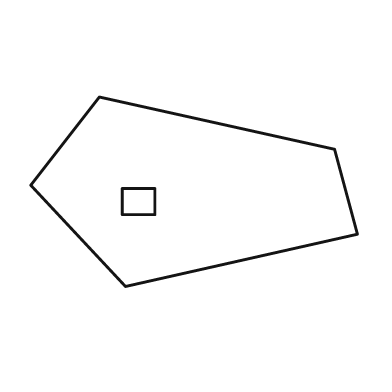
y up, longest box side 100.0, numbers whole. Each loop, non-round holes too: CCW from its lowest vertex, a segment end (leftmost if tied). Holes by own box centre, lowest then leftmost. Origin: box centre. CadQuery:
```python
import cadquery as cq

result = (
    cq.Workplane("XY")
    .moveTo(-21.0, -29.0)
    .lineTo(50.0, -13.0)
    .lineTo(43.0, 13.0)
    .lineTo(-29.0, 29.0)
    .lineTo(-50.0, 2.0)
    .close()
    .moveTo(-22.0, -7.0)
    .lineTo(-12.0, -7.0)
    .lineTo(-12.0, 1.0)
    .lineTo(-22.0, 1.0)
    .close()
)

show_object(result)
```